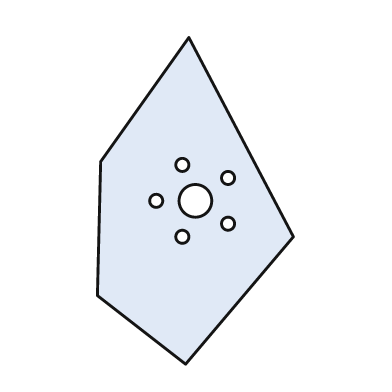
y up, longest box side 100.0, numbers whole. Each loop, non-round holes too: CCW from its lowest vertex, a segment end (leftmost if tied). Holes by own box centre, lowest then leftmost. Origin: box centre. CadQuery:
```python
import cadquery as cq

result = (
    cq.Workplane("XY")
    .moveTo(-3.0, -50.0)
    .lineTo(30.0, -11.0)
    .lineTo(-2.0, 50.0)
    .lineTo(-29.0, 12.0)
    .lineTo(-30.0, -29.0)
    .close()
    .moveTo(-4.0, -11.0)
    .circle(2.0)
    .moveTo(10.0, -7.0)
    .circle(2.0)
    .moveTo(-12.0, 0.0)
    .circle(2.0)
    .moveTo(0.0, 0.0)
    .circle(5.0)
    .moveTo(10.0, 7.0)
    .circle(2.0)
    .moveTo(-4.0, 11.0)
    .circle(2.0)
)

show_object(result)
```